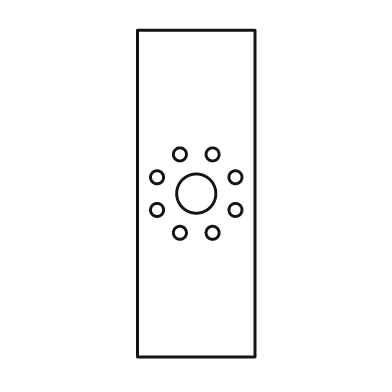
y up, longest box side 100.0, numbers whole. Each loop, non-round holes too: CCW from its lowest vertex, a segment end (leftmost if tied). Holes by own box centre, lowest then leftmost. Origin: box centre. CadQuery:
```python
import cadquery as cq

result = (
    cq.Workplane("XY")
    .moveTo(-18.0, -50.0)
    .lineTo(18.0, -50.0)
    .lineTo(18.0, 50.0)
    .lineTo(-18.0, 50.0)
    .close()
    .moveTo(-5.0, -12.0)
    .circle(2.0)
    .moveTo(5.0, -12.0)
    .circle(2.0)
    .moveTo(-12.0, -5.0)
    .circle(2.0)
    .moveTo(12.0, -5.0)
    .circle(2.0)
    .moveTo(0.0, 0.0)
    .circle(6.0)
    .moveTo(-12.0, 5.0)
    .circle(2.0)
    .moveTo(12.0, 5.0)
    .circle(2.0)
    .moveTo(-5.0, 12.0)
    .circle(2.0)
    .moveTo(5.0, 12.0)
    .circle(2.0)
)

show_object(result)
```